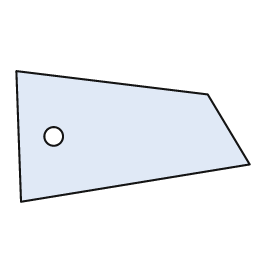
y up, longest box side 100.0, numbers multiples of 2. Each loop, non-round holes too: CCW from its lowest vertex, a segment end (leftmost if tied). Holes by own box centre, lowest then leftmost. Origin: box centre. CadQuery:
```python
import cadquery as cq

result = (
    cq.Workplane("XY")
    .moveTo(-48.0, -28.0)
    .lineTo(50.0, -12.0)
    .lineTo(32.0, 18.0)
    .lineTo(-50.0, 28.0)
    .close()
    .moveTo(-34.0, 0.0)
    .circle(4.0)
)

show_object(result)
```